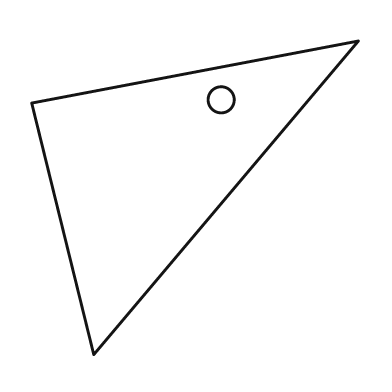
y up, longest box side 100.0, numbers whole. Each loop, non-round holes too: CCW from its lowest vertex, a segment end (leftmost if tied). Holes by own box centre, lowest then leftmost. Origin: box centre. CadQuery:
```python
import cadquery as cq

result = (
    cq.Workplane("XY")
    .moveTo(-31.0, -48.0)
    .lineTo(50.0, 48.0)
    .lineTo(-50.0, 29.0)
    .close()
    .moveTo(8.0, 30.0)
    .circle(4.0)
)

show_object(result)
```